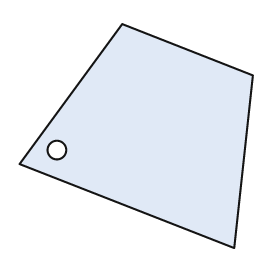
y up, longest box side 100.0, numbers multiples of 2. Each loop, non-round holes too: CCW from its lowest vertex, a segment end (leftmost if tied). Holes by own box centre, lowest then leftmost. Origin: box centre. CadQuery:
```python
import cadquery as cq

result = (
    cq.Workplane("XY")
    .moveTo(42.0, -48.0)
    .lineTo(50.0, 26.0)
    .lineTo(-6.0, 48.0)
    .lineTo(-50.0, -12.0)
    .close()
    .moveTo(-34.0, -6.0)
    .circle(4.0)
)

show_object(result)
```